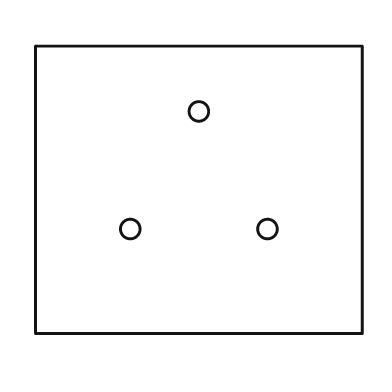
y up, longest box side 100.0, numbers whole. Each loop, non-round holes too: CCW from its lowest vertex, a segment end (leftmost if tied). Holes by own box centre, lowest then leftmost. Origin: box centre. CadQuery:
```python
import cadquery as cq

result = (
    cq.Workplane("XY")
    .moveTo(-50.0, -44.0)
    .lineTo(50.0, -44.0)
    .lineTo(50.0, 44.0)
    .lineTo(-50.0, 44.0)
    .close()
    .moveTo(-21.0, -12.0)
    .circle(3.0)
    .moveTo(21.0, -12.0)
    .circle(3.0)
    .moveTo(0.0, 24.0)
    .circle(3.0)
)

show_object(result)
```